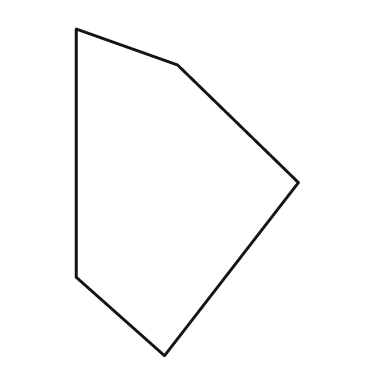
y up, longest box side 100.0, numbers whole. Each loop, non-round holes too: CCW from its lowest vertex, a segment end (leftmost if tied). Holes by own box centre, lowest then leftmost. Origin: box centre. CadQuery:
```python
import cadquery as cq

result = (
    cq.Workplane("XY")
    .moveTo(-7.0, -50.0)
    .lineTo(34.0, 3.0)
    .lineTo(-3.0, 39.0)
    .lineTo(-34.0, 50.0)
    .lineTo(-34.0, -26.0)
    .close()
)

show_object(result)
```